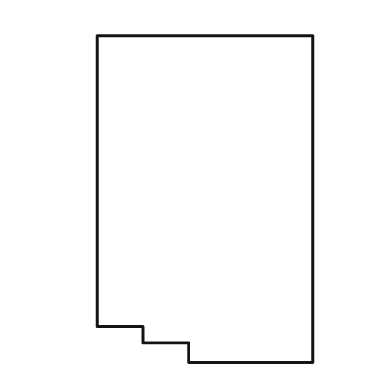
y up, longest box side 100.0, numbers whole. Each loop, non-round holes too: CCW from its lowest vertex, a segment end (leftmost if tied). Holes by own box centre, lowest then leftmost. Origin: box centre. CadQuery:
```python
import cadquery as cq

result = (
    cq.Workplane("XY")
    .moveTo(-5.0, -50.0)
    .lineTo(33.0, -50.0)
    .lineTo(33.0, 50.0)
    .lineTo(-33.0, 50.0)
    .lineTo(-33.0, -39.0)
    .lineTo(-19.0, -39.0)
    .lineTo(-19.0, -44.0)
    .lineTo(-5.0, -44.0)
    .close()
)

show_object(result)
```